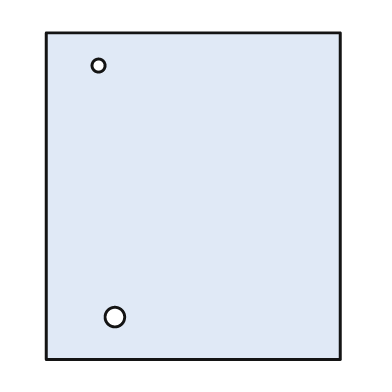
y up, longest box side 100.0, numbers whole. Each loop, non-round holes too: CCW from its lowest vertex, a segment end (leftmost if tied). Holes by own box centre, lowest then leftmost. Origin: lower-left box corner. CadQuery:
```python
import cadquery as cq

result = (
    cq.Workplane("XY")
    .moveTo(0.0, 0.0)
    .lineTo(90.0, 0.0)
    .lineTo(90.0, 100.0)
    .lineTo(0.0, 100.0)
    .close()
    .moveTo(21.0, 13.0)
    .circle(3.0)
    .moveTo(16.0, 90.0)
    .circle(2.0)
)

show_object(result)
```